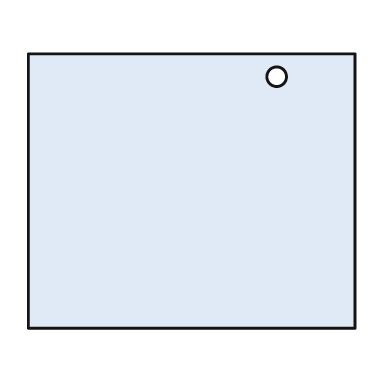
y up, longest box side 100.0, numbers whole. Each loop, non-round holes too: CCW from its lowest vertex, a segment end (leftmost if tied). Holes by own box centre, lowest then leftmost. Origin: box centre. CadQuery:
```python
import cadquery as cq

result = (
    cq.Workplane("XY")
    .moveTo(-50.0, -42.0)
    .lineTo(50.0, -42.0)
    .lineTo(50.0, 42.0)
    .lineTo(-50.0, 42.0)
    .close()
    .moveTo(26.0, 35.0)
    .circle(3.0)
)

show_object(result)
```